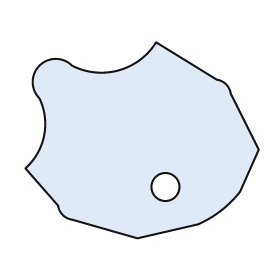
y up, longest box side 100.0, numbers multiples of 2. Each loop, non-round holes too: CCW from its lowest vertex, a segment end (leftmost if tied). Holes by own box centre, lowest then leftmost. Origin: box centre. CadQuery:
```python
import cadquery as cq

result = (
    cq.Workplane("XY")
    .moveTo(-2.0, -42.0)
    .lineTo(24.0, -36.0)
    .threePointArc((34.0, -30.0), (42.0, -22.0))
    .lineTo(50.0, -4.0)
    .lineTo(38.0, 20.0)
    .threePointArc((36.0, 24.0), (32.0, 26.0))
    .lineTo(6.0, 42.0)
    .threePointArc((-10.0, 30.0), (-30.0, 32.0))
    .threePointArc((-44.0, 32.0), (-44.0, 18.0))
    .threePointArc((-42.0, 2.0), (-50.0, -12.0))
    .lineTo(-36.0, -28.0)
    .threePointArc((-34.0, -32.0), (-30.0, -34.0))
    .close()
    .moveTo(10.0, -20.0)
    .circle(6.0)
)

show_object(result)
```